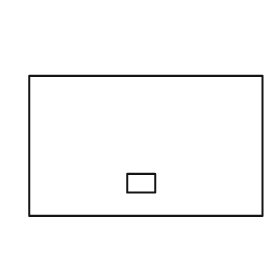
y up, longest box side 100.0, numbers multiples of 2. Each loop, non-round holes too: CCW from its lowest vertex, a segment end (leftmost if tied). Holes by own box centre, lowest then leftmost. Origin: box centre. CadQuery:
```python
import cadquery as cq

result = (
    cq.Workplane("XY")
    .moveTo(-50.0, -30.0)
    .lineTo(50.0, -30.0)
    .lineTo(50.0, 30.0)
    .lineTo(-50.0, 30.0)
    .close()
    .moveTo(-8.0, -20.0)
    .lineTo(4.0, -20.0)
    .lineTo(4.0, -12.0)
    .lineTo(-8.0, -12.0)
    .close()
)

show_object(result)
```